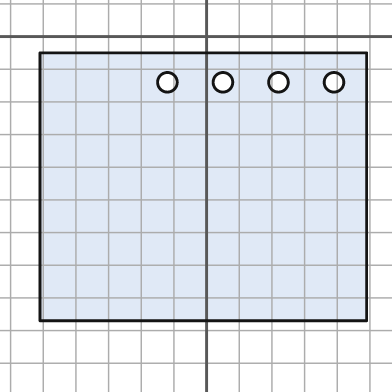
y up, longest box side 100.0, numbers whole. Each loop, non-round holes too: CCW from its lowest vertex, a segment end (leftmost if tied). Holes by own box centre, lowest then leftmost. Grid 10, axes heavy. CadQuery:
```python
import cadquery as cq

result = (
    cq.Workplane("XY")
    .moveTo(-51.0, -87.0)
    .lineTo(49.0, -87.0)
    .lineTo(49.0, -5.0)
    .lineTo(-51.0, -5.0)
    .close()
    .moveTo(-12.0, -14.0)
    .circle(3.0)
    .moveTo(5.0, -14.0)
    .circle(3.0)
    .moveTo(22.0, -14.0)
    .circle(3.0)
    .moveTo(39.0, -14.0)
    .circle(3.0)
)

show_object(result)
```